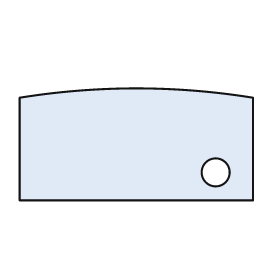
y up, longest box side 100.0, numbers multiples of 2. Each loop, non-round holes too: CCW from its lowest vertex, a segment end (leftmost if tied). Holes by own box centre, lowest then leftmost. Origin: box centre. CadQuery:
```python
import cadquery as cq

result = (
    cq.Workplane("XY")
    .moveTo(-50.0, -24.0)
    .lineTo(50.0, -24.0)
    .lineTo(50.0, 20.0)
    .threePointArc((0.0, 24.0), (-50.0, 20.0))
    .close()
    .moveTo(34.0, -12.0)
    .circle(6.0)
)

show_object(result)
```